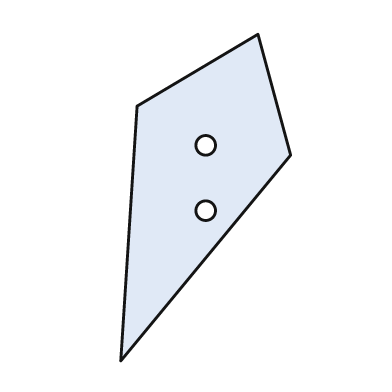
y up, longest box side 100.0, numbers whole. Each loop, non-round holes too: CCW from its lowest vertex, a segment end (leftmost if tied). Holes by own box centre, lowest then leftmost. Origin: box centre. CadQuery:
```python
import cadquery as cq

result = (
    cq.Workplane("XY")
    .moveTo(-26.0, -50.0)
    .lineTo(26.0, 13.0)
    .lineTo(16.0, 50.0)
    .lineTo(-21.0, 28.0)
    .close()
    .moveTo(0.0, -4.0)
    .circle(3.0)
    .moveTo(0.0, 16.0)
    .circle(3.0)
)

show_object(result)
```